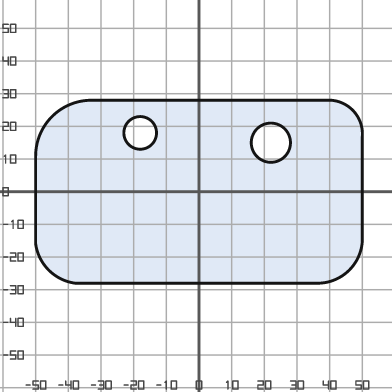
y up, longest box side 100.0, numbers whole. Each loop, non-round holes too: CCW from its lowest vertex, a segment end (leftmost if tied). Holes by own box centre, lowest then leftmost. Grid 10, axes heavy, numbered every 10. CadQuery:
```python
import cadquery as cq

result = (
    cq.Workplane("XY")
    .moveTo(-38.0, -28.0)
    .lineTo(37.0, -28.0)
    .threePointArc((46.0, -24.0), (50.0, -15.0))
    .lineTo(50.0, 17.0)
    .threePointArc((47.0, 25.0), (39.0, 28.0))
    .lineTo(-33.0, 28.0)
    .threePointArc((-45.0, 23.0), (-50.0, 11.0))
    .lineTo(-50.0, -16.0)
    .threePointArc((-46.0, -24.0), (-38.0, -28.0))
    .close()
    .moveTo(22.0, 15.0)
    .circle(6.0)
    .moveTo(-18.0, 18.0)
    .circle(5.0)
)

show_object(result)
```